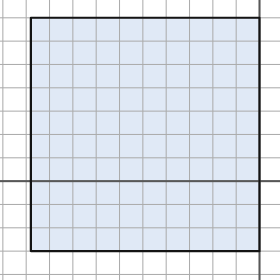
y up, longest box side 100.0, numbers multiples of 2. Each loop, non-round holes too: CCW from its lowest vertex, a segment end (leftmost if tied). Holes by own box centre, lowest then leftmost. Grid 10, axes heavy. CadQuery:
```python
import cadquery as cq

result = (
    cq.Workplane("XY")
    .moveTo(-98.0, -30.0)
    .lineTo(0.0, -30.0)
    .lineTo(0.0, 70.0)
    .lineTo(-98.0, 70.0)
    .close()
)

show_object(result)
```